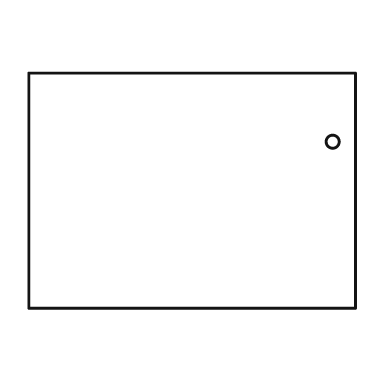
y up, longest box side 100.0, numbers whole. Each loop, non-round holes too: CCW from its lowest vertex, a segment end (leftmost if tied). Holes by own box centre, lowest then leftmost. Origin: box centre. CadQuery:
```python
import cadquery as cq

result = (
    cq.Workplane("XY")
    .moveTo(-50.0, -36.0)
    .lineTo(50.0, -36.0)
    .lineTo(50.0, 36.0)
    .lineTo(-50.0, 36.0)
    .close()
    .moveTo(43.0, 15.0)
    .circle(2.0)
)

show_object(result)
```